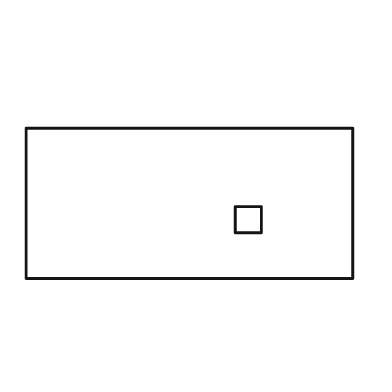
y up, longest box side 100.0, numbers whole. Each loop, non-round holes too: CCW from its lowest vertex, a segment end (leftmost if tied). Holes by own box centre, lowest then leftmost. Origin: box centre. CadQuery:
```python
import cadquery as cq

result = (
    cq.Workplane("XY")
    .moveTo(-50.0, -23.0)
    .lineTo(50.0, -23.0)
    .lineTo(50.0, 23.0)
    .lineTo(-50.0, 23.0)
    .close()
    .moveTo(14.0, -9.0)
    .lineTo(22.0, -9.0)
    .lineTo(22.0, -1.0)
    .lineTo(14.0, -1.0)
    .close()
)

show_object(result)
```